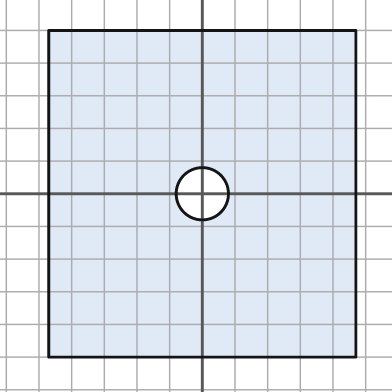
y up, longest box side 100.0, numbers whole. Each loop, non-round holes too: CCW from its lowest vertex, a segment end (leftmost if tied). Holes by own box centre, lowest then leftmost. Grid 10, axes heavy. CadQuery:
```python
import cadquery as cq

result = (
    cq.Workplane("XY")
    .moveTo(-47.0, -50.0)
    .lineTo(47.0, -50.0)
    .lineTo(47.0, 50.0)
    .lineTo(-47.0, 50.0)
    .close()
    .moveTo(0.0, 0.0)
    .circle(8.0)
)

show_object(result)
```